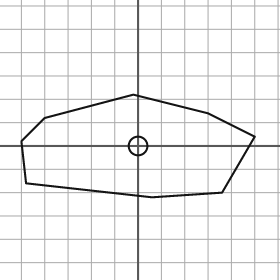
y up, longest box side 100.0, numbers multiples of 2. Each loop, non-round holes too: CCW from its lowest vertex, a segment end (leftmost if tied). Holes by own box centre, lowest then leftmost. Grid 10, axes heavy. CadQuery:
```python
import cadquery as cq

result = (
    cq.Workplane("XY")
    .moveTo(6.0, -22.0)
    .lineTo(36.0, -20.0)
    .lineTo(50.0, 4.0)
    .lineTo(30.0, 14.0)
    .lineTo(-2.0, 22.0)
    .lineTo(-40.0, 12.0)
    .lineTo(-50.0, 2.0)
    .lineTo(-48.0, -16.0)
    .close()
    .moveTo(0.0, 0.0)
    .circle(4.0)
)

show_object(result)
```